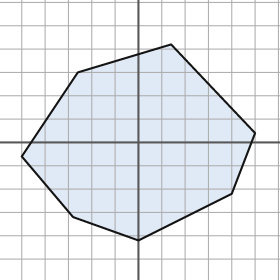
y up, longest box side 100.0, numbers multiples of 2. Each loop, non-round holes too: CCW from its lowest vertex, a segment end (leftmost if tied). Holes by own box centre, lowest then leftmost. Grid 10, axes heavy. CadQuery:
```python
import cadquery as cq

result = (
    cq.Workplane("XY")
    .moveTo(0.0, -42.0)
    .lineTo(40.0, -22.0)
    .lineTo(50.0, 4.0)
    .lineTo(14.0, 42.0)
    .lineTo(-26.0, 30.0)
    .lineTo(-50.0, -6.0)
    .lineTo(-28.0, -32.0)
    .close()
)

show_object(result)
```